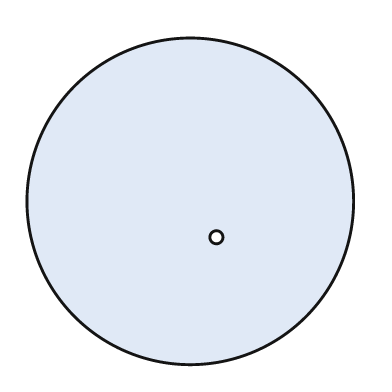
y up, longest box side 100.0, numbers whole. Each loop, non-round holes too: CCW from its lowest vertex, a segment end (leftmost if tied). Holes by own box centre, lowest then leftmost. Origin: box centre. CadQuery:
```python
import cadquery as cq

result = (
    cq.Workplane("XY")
    .moveTo(0.0, 0.0)
    .circle(50.0)
    .moveTo(8.0, -11.0)
    .circle(2.0)
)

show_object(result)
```